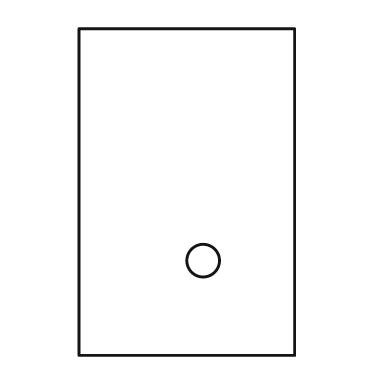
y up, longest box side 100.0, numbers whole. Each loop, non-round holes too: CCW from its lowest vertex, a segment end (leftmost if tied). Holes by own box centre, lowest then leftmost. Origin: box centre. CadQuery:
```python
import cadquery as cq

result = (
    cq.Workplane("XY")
    .moveTo(-33.0, -50.0)
    .lineTo(33.0, -50.0)
    .lineTo(33.0, 50.0)
    .lineTo(-33.0, 50.0)
    .close()
    .moveTo(5.0, -21.0)
    .circle(5.0)
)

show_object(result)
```